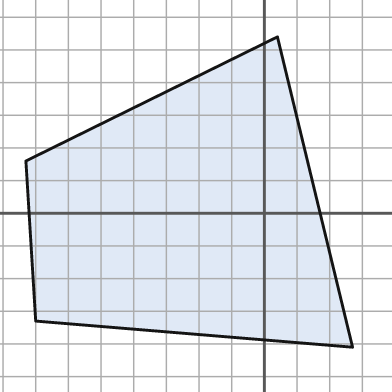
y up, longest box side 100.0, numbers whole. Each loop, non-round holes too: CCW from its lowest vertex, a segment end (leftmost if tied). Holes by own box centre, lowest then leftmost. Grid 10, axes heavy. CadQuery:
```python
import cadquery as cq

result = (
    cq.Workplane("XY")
    .moveTo(27.0, -41.0)
    .lineTo(4.0, 54.0)
    .lineTo(-73.0, 16.0)
    .lineTo(-70.0, -33.0)
    .close()
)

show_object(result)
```